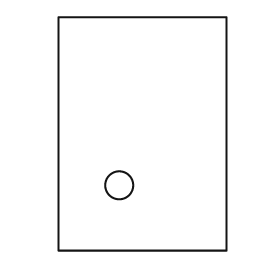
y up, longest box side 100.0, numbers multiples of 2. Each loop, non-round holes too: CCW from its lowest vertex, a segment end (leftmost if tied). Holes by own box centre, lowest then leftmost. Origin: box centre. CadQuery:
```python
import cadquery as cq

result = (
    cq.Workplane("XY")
    .moveTo(-36.0, -50.0)
    .lineTo(36.0, -50.0)
    .lineTo(36.0, 50.0)
    .lineTo(-36.0, 50.0)
    .close()
    .moveTo(-10.0, -22.0)
    .circle(6.0)
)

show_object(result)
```